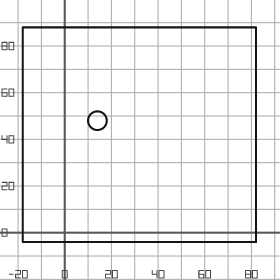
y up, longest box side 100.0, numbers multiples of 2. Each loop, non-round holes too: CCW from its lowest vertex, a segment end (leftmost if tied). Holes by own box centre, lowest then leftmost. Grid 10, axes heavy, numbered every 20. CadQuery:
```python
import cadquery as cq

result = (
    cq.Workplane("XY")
    .moveTo(-18.0, -4.0)
    .lineTo(82.0, -4.0)
    .lineTo(82.0, 88.0)
    .lineTo(-18.0, 88.0)
    .close()
    .moveTo(14.0, 48.0)
    .circle(4.0)
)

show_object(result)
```